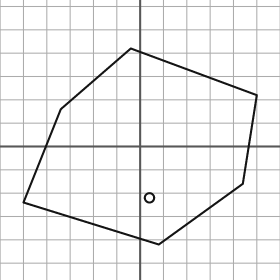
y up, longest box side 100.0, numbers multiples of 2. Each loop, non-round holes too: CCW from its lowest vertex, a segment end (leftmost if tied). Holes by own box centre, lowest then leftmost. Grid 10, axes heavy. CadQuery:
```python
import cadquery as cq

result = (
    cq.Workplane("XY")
    .moveTo(8.0, -42.0)
    .lineTo(44.0, -16.0)
    .lineTo(50.0, 22.0)
    .lineTo(-4.0, 42.0)
    .lineTo(-34.0, 16.0)
    .lineTo(-50.0, -24.0)
    .close()
    .moveTo(4.0, -22.0)
    .circle(2.0)
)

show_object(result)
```